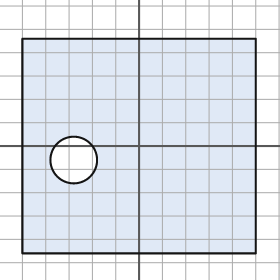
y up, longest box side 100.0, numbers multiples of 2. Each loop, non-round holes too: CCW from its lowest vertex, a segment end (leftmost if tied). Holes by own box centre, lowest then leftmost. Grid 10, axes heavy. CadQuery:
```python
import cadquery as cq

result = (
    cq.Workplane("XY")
    .moveTo(-50.0, -46.0)
    .lineTo(50.0, -46.0)
    .lineTo(50.0, 46.0)
    .lineTo(-50.0, 46.0)
    .close()
    .moveTo(-28.0, -6.0)
    .circle(10.0)
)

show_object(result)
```